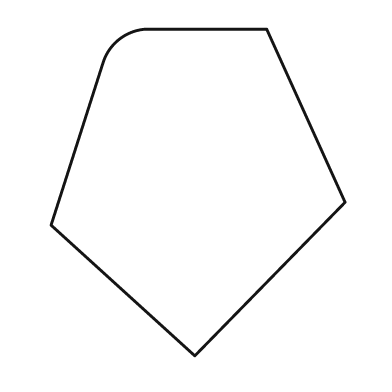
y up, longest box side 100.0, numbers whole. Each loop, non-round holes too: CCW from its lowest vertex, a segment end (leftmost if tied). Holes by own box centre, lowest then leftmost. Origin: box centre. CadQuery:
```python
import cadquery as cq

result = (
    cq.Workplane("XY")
    .moveTo(-1.0, -50.0)
    .lineTo(45.0, -3.0)
    .lineTo(21.0, 50.0)
    .lineTo(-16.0, 50.0)
    .threePointArc((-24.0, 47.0), (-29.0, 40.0))
    .lineTo(-45.0, -10.0)
    .close()
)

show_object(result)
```